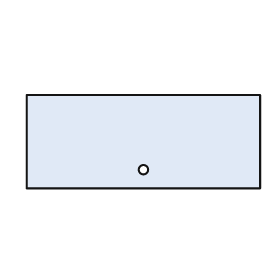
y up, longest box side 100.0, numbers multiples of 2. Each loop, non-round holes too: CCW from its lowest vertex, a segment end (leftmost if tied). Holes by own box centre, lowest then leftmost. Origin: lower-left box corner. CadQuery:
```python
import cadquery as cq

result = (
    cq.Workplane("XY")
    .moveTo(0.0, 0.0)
    .lineTo(100.0, 0.0)
    .lineTo(100.0, 40.0)
    .lineTo(0.0, 40.0)
    .close()
    .moveTo(50.0, 8.0)
    .circle(2.0)
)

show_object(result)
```